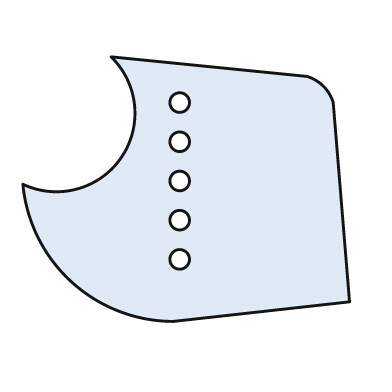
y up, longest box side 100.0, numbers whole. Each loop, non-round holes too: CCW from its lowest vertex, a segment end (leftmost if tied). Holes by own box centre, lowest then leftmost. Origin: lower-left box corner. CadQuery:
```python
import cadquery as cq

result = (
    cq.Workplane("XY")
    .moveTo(46.0, 0.0)
    .lineTo(100.0, 6.0)
    .lineTo(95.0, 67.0)
    .threePointArc((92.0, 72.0), (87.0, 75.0))
    .lineTo(27.0, 81.0)
    .threePointArc((30.0, 50.0), (0.0, 42.0))
    .threePointArc((15.0, 12.0), (46.0, 0.0))
    .close()
    .moveTo(48.0, 19.0)
    .circle(3.0)
    .moveTo(48.0, 31.0)
    .circle(3.0)
    .moveTo(48.0, 43.0)
    .circle(3.0)
    .moveTo(48.0, 55.0)
    .circle(3.0)
    .moveTo(48.0, 67.0)
    .circle(3.0)
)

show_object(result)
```